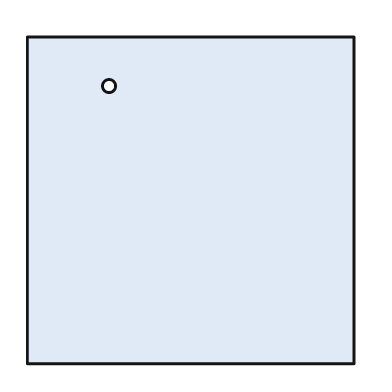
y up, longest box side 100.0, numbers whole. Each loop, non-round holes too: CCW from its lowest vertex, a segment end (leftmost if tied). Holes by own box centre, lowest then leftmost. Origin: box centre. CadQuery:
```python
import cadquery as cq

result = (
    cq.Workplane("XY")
    .moveTo(-50.0, -50.0)
    .lineTo(50.0, -50.0)
    .lineTo(50.0, 50.0)
    .lineTo(-50.0, 50.0)
    .close()
    .moveTo(-25.0, 35.0)
    .circle(2.0)
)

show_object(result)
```